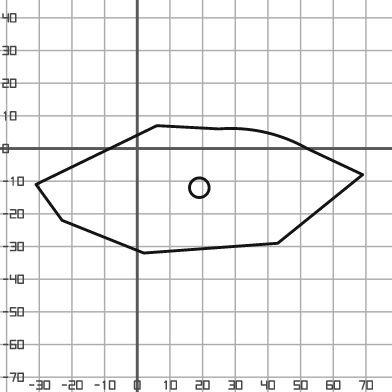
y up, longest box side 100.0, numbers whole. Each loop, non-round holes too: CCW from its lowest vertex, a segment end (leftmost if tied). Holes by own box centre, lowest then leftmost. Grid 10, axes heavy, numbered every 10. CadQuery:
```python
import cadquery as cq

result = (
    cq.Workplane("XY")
    .moveTo(2.0, -32.0)
    .lineTo(43.0, -29.0)
    .lineTo(69.0, -8.0)
    .lineTo(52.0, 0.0)
    .threePointArc((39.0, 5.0), (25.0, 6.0))
    .lineTo(6.0, 7.0)
    .lineTo(-31.0, -11.0)
    .lineTo(-23.0, -22.0)
    .close()
    .moveTo(19.0, -12.0)
    .circle(3.0)
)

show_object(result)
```